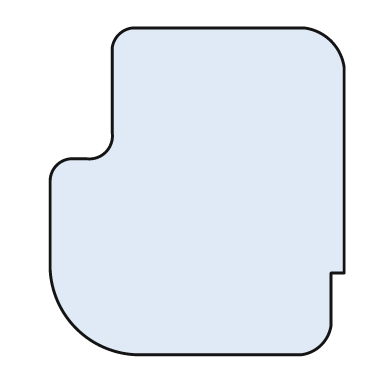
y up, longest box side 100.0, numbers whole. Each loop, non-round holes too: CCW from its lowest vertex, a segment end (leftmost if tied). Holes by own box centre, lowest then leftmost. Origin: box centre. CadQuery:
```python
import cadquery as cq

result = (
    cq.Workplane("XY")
    .moveTo(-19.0, -50.0)
    .lineTo(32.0, -50.0)
    .threePointArc((38.0, -47.0), (41.0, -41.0))
    .lineTo(41.0, -25.0)
    .lineTo(45.0, -25.0)
    .lineTo(45.0, 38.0)
    .threePointArc((41.0, 46.0), (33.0, 50.0))
    .lineTo(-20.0, 50.0)
    .threePointArc((-24.0, 48.0), (-26.0, 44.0))
    .lineTo(-26.0, 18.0)
    .threePointArc((-28.0, 12.0), (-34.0, 10.0))
    .lineTo(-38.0, 10.0)
    .threePointArc((-43.0, 8.0), (-45.0, 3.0))
    .lineTo(-45.0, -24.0)
    .threePointArc((-37.0, -42.0), (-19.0, -50.0))
    .close()
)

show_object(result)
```